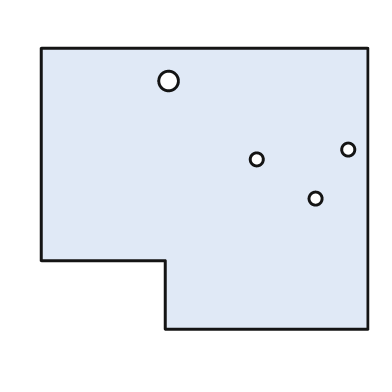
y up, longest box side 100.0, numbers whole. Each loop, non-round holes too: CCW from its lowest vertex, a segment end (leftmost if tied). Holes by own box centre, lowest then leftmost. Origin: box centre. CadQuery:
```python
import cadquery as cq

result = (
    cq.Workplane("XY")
    .moveTo(-12.0, -43.0)
    .lineTo(50.0, -43.0)
    .lineTo(50.0, 43.0)
    .lineTo(-50.0, 43.0)
    .lineTo(-50.0, -22.0)
    .lineTo(-12.0, -22.0)
    .close()
    .moveTo(34.0, -3.0)
    .circle(2.0)
    .moveTo(16.0, 9.0)
    .circle(2.0)
    .moveTo(44.0, 12.0)
    .circle(2.0)
    .moveTo(-11.0, 33.0)
    .circle(3.0)
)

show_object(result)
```